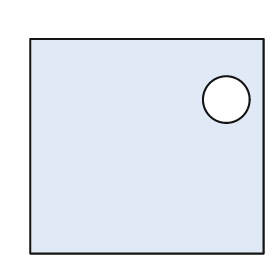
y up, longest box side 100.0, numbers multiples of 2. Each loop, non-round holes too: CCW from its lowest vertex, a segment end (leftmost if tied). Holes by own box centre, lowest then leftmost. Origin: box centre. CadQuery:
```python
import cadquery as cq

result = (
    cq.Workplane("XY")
    .moveTo(-50.0, -46.0)
    .lineTo(50.0, -46.0)
    .lineTo(50.0, 46.0)
    .lineTo(-50.0, 46.0)
    .close()
    .moveTo(34.0, 20.0)
    .circle(10.0)
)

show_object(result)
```